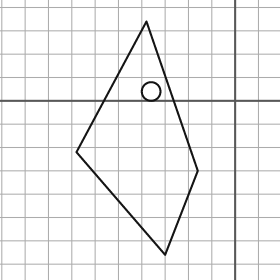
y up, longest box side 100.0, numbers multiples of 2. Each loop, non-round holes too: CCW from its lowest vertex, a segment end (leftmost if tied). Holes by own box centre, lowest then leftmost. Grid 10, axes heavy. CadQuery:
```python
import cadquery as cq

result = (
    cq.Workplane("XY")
    .moveTo(-30.0, -66.0)
    .lineTo(-16.0, -30.0)
    .lineTo(-38.0, 34.0)
    .lineTo(-68.0, -22.0)
    .close()
    .moveTo(-36.0, 4.0)
    .circle(4.0)
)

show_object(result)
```